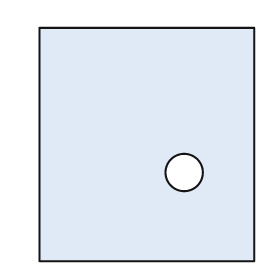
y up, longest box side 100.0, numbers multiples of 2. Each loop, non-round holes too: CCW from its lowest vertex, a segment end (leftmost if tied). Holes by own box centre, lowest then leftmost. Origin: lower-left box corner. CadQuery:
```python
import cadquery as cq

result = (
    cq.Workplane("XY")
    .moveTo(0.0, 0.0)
    .lineTo(92.0, 0.0)
    .lineTo(92.0, 100.0)
    .lineTo(0.0, 100.0)
    .close()
    .moveTo(62.0, 38.0)
    .circle(8.0)
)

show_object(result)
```